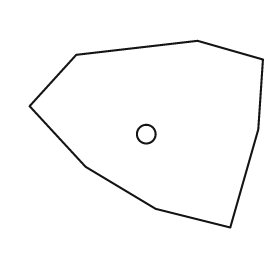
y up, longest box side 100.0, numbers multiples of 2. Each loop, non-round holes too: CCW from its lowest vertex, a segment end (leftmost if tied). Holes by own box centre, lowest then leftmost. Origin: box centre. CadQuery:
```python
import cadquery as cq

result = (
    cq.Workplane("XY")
    .moveTo(36.0, -40.0)
    .lineTo(48.0, 2.0)
    .lineTo(50.0, 32.0)
    .lineTo(22.0, 40.0)
    .lineTo(-30.0, 34.0)
    .lineTo(-50.0, 12.0)
    .lineTo(-26.0, -14.0)
    .lineTo(4.0, -32.0)
    .close()
    .moveTo(0.0, 0.0)
    .circle(4.0)
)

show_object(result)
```